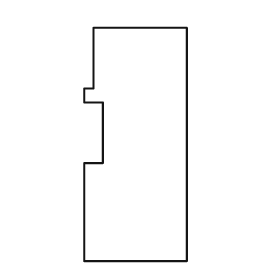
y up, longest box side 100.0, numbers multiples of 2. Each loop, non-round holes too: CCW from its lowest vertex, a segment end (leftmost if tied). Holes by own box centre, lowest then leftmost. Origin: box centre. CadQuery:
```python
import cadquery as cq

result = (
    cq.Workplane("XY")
    .moveTo(-22.0, -50.0)
    .lineTo(22.0, -50.0)
    .lineTo(22.0, 50.0)
    .lineTo(-18.0, 50.0)
    .lineTo(-18.0, 24.0)
    .lineTo(-22.0, 24.0)
    .lineTo(-22.0, 18.0)
    .lineTo(-14.0, 18.0)
    .lineTo(-14.0, -8.0)
    .lineTo(-22.0, -8.0)
    .close()
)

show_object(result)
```